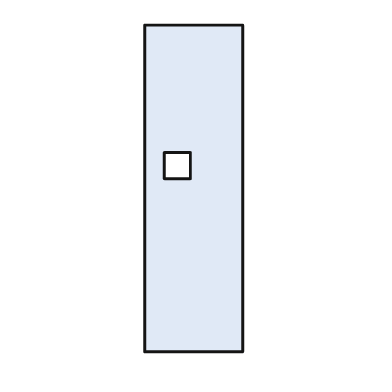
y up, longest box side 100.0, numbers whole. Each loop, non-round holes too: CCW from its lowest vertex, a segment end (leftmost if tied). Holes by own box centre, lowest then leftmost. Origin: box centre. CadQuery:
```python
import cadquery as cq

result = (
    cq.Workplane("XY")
    .moveTo(-15.0, -50.0)
    .lineTo(15.0, -50.0)
    .lineTo(15.0, 50.0)
    .lineTo(-15.0, 50.0)
    .close()
    .moveTo(-9.0, 3.0)
    .lineTo(-1.0, 3.0)
    .lineTo(-1.0, 11.0)
    .lineTo(-9.0, 11.0)
    .close()
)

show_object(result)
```